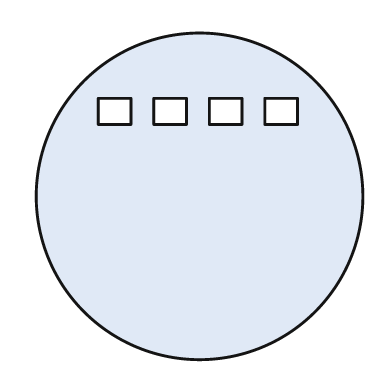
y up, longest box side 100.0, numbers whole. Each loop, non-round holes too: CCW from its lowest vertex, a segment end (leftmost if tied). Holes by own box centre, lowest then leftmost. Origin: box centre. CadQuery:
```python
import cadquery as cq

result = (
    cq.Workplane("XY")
    .moveTo(0.0, 0.0)
    .circle(50.0)
    .moveTo(-31.0, 22.0)
    .lineTo(-21.0, 22.0)
    .lineTo(-21.0, 30.0)
    .lineTo(-31.0, 30.0)
    .close()
    .moveTo(-14.0, 22.0)
    .lineTo(-4.0, 22.0)
    .lineTo(-4.0, 30.0)
    .lineTo(-14.0, 30.0)
    .close()
    .moveTo(3.0, 22.0)
    .lineTo(13.0, 22.0)
    .lineTo(13.0, 30.0)
    .lineTo(3.0, 30.0)
    .close()
    .moveTo(20.0, 22.0)
    .lineTo(30.0, 22.0)
    .lineTo(30.0, 30.0)
    .lineTo(20.0, 30.0)
    .close()
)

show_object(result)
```